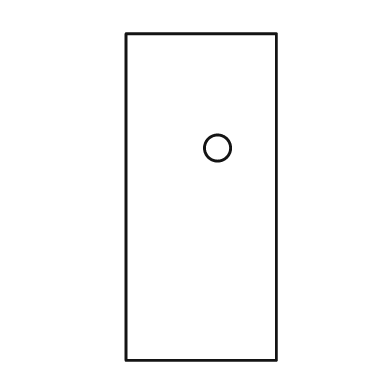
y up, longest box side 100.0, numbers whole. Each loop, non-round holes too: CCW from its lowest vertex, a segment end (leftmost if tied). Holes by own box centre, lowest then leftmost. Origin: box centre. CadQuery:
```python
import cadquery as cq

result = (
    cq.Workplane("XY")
    .moveTo(-23.0, -50.0)
    .lineTo(23.0, -50.0)
    .lineTo(23.0, 50.0)
    .lineTo(-23.0, 50.0)
    .close()
    .moveTo(5.0, 15.0)
    .circle(4.0)
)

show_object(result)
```